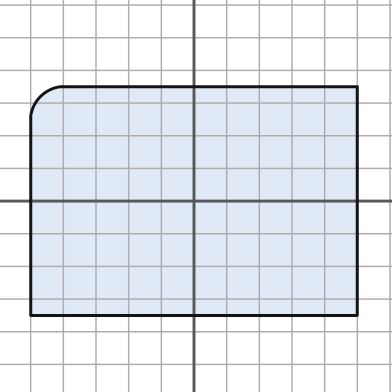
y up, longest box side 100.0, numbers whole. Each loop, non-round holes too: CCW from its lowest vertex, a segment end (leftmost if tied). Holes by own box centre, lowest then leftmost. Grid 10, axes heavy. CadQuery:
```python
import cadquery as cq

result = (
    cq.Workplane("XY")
    .moveTo(-50.0, -35.0)
    .lineTo(50.0, -35.0)
    .lineTo(50.0, 35.0)
    .lineTo(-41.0, 35.0)
    .threePointArc((-47.0, 32.0), (-50.0, 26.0))
    .close()
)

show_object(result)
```